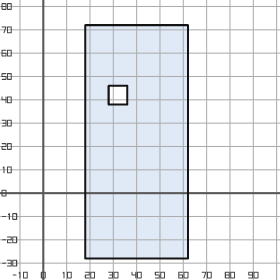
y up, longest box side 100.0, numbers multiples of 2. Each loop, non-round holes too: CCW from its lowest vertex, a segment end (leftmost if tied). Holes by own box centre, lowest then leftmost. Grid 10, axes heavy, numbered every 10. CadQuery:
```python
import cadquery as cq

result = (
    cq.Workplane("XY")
    .moveTo(18.0, -28.0)
    .lineTo(62.0, -28.0)
    .lineTo(62.0, 72.0)
    .lineTo(18.0, 72.0)
    .close()
    .moveTo(28.0, 38.0)
    .lineTo(36.0, 38.0)
    .lineTo(36.0, 46.0)
    .lineTo(28.0, 46.0)
    .close()
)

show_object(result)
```